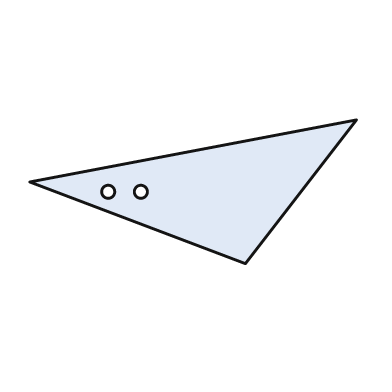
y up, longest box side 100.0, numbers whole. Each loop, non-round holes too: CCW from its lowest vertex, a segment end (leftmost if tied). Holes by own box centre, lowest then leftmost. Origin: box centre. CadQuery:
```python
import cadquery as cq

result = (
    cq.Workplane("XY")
    .moveTo(16.0, -22.0)
    .lineTo(50.0, 22.0)
    .lineTo(-50.0, 3.0)
    .close()
    .moveTo(-26.0, 0.0)
    .circle(2.0)
    .moveTo(-16.0, 0.0)
    .circle(2.0)
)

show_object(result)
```